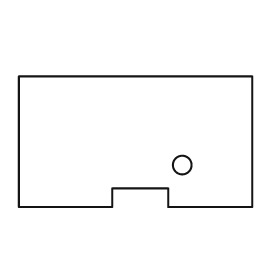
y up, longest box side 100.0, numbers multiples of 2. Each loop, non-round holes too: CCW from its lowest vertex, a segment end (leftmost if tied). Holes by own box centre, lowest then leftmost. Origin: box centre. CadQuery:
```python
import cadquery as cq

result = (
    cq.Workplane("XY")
    .moveTo(-50.0, -28.0)
    .lineTo(-10.0, -28.0)
    .lineTo(-10.0, -20.0)
    .lineTo(14.0, -20.0)
    .lineTo(14.0, -28.0)
    .lineTo(50.0, -28.0)
    .lineTo(50.0, 28.0)
    .lineTo(-50.0, 28.0)
    .close()
    .moveTo(20.0, -10.0)
    .circle(4.0)
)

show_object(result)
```